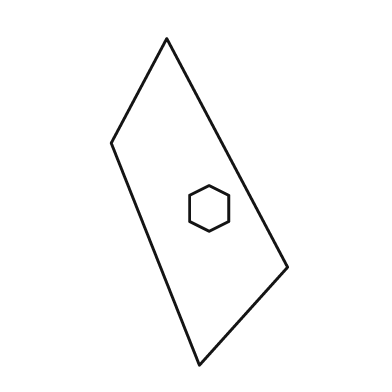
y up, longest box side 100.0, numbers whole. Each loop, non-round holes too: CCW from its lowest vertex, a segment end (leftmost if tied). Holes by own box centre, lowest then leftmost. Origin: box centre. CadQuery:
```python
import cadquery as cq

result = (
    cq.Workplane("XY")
    .moveTo(0.0, -50.0)
    .lineTo(27.0, -20.0)
    .lineTo(-10.0, 50.0)
    .lineTo(-27.0, 18.0)
    .close()
    .moveTo(3.0, -9.0)
    .lineTo(9.0, -6.0)
    .lineTo(9.0, 2.0)
    .lineTo(3.0, 5.0)
    .lineTo(-3.0, 2.0)
    .lineTo(-3.0, -6.0)
    .close()
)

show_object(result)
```